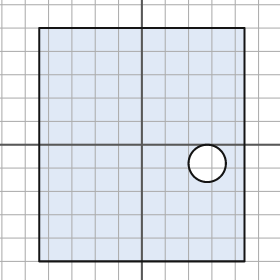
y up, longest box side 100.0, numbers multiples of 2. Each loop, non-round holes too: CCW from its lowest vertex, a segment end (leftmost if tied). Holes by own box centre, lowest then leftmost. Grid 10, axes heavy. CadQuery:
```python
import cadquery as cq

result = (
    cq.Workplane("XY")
    .moveTo(-44.0, -50.0)
    .lineTo(44.0, -50.0)
    .lineTo(44.0, 50.0)
    .lineTo(-44.0, 50.0)
    .close()
    .moveTo(28.0, -8.0)
    .circle(8.0)
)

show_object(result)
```